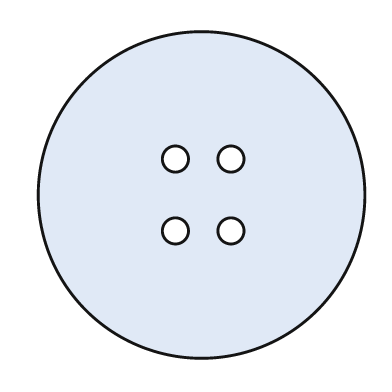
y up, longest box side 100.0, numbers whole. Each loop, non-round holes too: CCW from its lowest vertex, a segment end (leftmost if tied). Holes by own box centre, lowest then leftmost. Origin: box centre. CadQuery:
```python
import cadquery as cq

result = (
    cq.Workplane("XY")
    .moveTo(0.0, 0.0)
    .circle(50.0)
    .moveTo(-8.0, -11.0)
    .circle(4.0)
    .moveTo(9.0, -11.0)
    .circle(4.0)
    .moveTo(-8.0, 11.0)
    .circle(4.0)
    .moveTo(9.0, 11.0)
    .circle(4.0)
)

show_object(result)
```